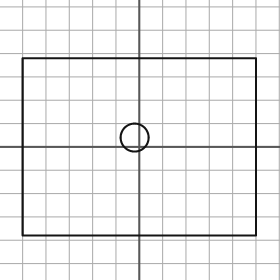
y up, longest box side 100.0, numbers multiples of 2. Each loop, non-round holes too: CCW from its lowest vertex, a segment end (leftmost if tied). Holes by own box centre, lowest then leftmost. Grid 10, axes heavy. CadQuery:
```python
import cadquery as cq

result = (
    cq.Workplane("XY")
    .moveTo(-50.0, -38.0)
    .lineTo(50.0, -38.0)
    .lineTo(50.0, 38.0)
    .lineTo(-50.0, 38.0)
    .close()
    .moveTo(-2.0, 4.0)
    .circle(6.0)
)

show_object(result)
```